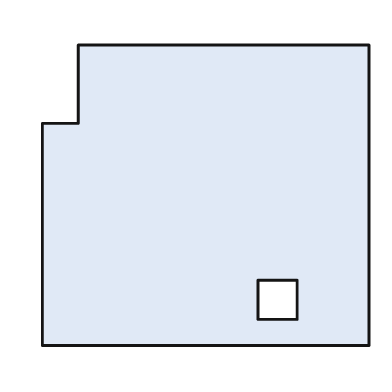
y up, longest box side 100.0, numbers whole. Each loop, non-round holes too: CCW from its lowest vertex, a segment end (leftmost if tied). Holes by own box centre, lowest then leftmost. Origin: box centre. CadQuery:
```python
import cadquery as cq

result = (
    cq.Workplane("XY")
    .moveTo(-50.0, -46.0)
    .lineTo(50.0, -46.0)
    .lineTo(50.0, 46.0)
    .lineTo(-39.0, 46.0)
    .lineTo(-39.0, 22.0)
    .lineTo(-50.0, 22.0)
    .close()
    .moveTo(16.0, -38.0)
    .lineTo(28.0, -38.0)
    .lineTo(28.0, -26.0)
    .lineTo(16.0, -26.0)
    .close()
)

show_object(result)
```